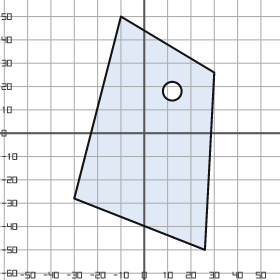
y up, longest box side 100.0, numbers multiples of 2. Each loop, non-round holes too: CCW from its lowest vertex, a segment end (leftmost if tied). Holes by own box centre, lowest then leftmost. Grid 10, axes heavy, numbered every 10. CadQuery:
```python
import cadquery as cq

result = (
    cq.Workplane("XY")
    .moveTo(26.0, -50.0)
    .lineTo(30.0, 26.0)
    .lineTo(-10.0, 50.0)
    .lineTo(-30.0, -28.0)
    .close()
    .moveTo(12.0, 18.0)
    .circle(4.0)
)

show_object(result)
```